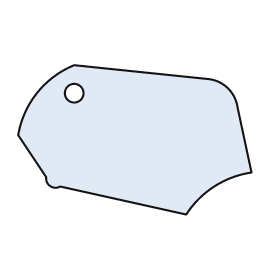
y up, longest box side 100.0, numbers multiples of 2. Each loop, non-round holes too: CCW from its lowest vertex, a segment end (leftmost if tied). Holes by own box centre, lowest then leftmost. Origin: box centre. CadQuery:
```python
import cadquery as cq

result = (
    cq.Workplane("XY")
    .moveTo(22.0, -32.0)
    .threePointArc((34.0, -20.0), (50.0, -14.0))
    .lineTo(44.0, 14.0)
    .threePointArc((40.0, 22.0), (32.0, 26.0))
    .lineTo(-26.0, 32.0)
    .threePointArc((-42.0, 20.0), (-50.0, 2.0))
    .lineTo(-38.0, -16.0)
    .threePointArc((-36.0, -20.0), (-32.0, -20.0))
    .close()
    .moveTo(-26.0, 20.0)
    .circle(4.0)
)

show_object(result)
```